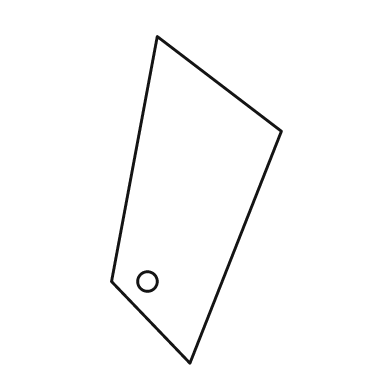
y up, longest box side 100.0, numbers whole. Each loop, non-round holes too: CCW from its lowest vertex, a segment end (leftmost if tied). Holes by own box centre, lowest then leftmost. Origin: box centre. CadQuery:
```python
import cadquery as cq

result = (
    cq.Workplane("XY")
    .moveTo(-2.0, -50.0)
    .lineTo(26.0, 21.0)
    .lineTo(-12.0, 50.0)
    .lineTo(-26.0, -25.0)
    .close()
    .moveTo(-15.0, -25.0)
    .circle(3.0)
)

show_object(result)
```